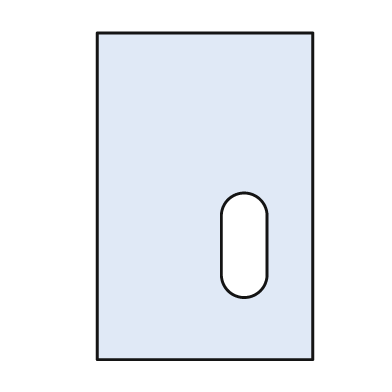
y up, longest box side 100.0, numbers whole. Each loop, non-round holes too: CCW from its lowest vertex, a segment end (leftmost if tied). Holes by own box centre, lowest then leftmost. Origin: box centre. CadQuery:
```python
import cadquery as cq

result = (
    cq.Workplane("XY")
    .moveTo(-33.0, -50.0)
    .lineTo(33.0, -50.0)
    .lineTo(33.0, 50.0)
    .lineTo(-33.0, 50.0)
    .close()
    .moveTo(5.0, -24.0)
    .threePointArc((12.0, -31.0), (19.0, -24.0))
    .lineTo(19.0, -6.0)
    .threePointArc((12.0, 1.0), (5.0, -6.0))
    .close()
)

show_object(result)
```